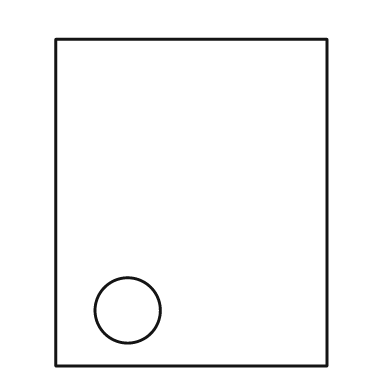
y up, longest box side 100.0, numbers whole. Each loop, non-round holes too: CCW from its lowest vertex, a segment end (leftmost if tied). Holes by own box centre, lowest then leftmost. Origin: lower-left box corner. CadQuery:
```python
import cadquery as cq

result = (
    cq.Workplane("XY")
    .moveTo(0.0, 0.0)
    .lineTo(83.0, 0.0)
    .lineTo(83.0, 100.0)
    .lineTo(0.0, 100.0)
    .close()
    .moveTo(22.0, 17.0)
    .circle(10.0)
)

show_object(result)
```